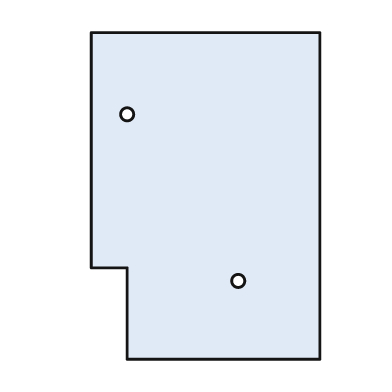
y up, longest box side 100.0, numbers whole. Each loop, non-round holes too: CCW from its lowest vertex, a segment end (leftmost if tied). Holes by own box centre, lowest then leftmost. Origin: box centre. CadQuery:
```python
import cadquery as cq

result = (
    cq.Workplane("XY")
    .moveTo(-24.0, -50.0)
    .lineTo(35.0, -50.0)
    .lineTo(35.0, 50.0)
    .lineTo(-35.0, 50.0)
    .lineTo(-35.0, -22.0)
    .lineTo(-24.0, -22.0)
    .close()
    .moveTo(10.0, -26.0)
    .circle(2.0)
    .moveTo(-24.0, 25.0)
    .circle(2.0)
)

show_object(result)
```